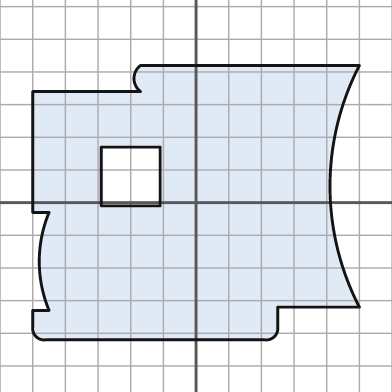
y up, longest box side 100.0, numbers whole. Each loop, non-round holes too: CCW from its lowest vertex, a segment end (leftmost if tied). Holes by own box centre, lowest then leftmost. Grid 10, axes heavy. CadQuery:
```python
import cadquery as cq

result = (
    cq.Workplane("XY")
    .moveTo(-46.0, -42.0)
    .lineTo(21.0, -42.0)
    .threePointArc((24.0, -41.0), (25.0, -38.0))
    .lineTo(25.0, -32.0)
    .lineTo(50.0, -32.0)
    .threePointArc((41.0, 5.0), (50.0, 42.0))
    .lineTo(-17.0, 42.0)
    .threePointArc((-19.0, 38.0), (-17.0, 34.0))
    .lineTo(-50.0, 34.0)
    .lineTo(-50.0, -3.0)
    .lineTo(-45.0, -3.0)
    .threePointArc((-48.0, -18.0), (-45.0, -33.0))
    .lineTo(-50.0, -33.0)
    .lineTo(-50.0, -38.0)
    .threePointArc((-49.0, -41.0), (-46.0, -42.0))
    .close()
    .moveTo(-29.0, -1.0)
    .lineTo(-11.0, -1.0)
    .lineTo(-11.0, 17.0)
    .lineTo(-29.0, 17.0)
    .close()
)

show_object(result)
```